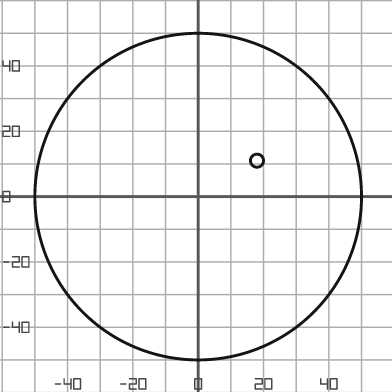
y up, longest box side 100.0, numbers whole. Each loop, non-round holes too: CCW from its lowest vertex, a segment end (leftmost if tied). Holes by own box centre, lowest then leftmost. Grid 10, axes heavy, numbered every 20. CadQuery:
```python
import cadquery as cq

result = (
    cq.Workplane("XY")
    .moveTo(0.0, 0.0)
    .circle(50.0)
    .moveTo(18.0, 11.0)
    .circle(2.0)
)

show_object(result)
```